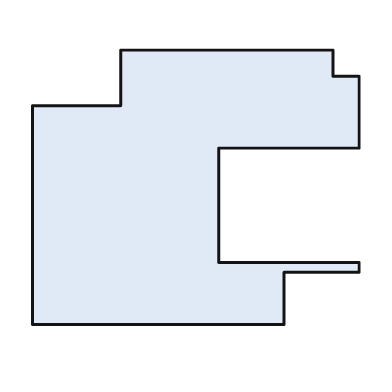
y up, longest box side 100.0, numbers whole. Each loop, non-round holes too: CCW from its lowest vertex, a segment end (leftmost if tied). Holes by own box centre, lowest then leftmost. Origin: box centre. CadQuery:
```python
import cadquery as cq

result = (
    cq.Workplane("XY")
    .moveTo(-50.0, -42.0)
    .lineTo(27.0, -42.0)
    .lineTo(27.0, -26.0)
    .lineTo(50.0, -26.0)
    .lineTo(50.0, -23.0)
    .lineTo(7.0, -23.0)
    .lineTo(7.0, 12.0)
    .lineTo(50.0, 12.0)
    .lineTo(50.0, 34.0)
    .lineTo(42.0, 34.0)
    .lineTo(42.0, 42.0)
    .lineTo(-23.0, 42.0)
    .lineTo(-23.0, 25.0)
    .lineTo(-50.0, 25.0)
    .close()
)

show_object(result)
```